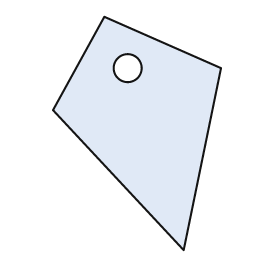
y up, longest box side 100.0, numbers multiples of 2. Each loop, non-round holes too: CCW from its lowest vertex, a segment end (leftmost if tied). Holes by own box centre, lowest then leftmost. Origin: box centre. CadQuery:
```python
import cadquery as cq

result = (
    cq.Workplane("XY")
    .moveTo(20.0, -50.0)
    .lineTo(36.0, 28.0)
    .lineTo(-14.0, 50.0)
    .lineTo(-36.0, 10.0)
    .close()
    .moveTo(-4.0, 28.0)
    .circle(6.0)
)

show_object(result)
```